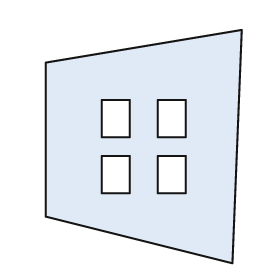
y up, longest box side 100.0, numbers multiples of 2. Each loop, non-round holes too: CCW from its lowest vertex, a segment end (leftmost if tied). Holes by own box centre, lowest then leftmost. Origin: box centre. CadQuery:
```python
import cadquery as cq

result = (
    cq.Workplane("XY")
    .moveTo(38.0, -50.0)
    .lineTo(42.0, 50.0)
    .lineTo(-42.0, 36.0)
    .lineTo(-42.0, -30.0)
    .close()
    .moveTo(-18.0, -20.0)
    .lineTo(-6.0, -20.0)
    .lineTo(-6.0, -4.0)
    .lineTo(-18.0, -4.0)
    .close()
    .moveTo(6.0, -20.0)
    .lineTo(18.0, -20.0)
    .lineTo(18.0, -4.0)
    .lineTo(6.0, -4.0)
    .close()
    .moveTo(-18.0, 4.0)
    .lineTo(-6.0, 4.0)
    .lineTo(-6.0, 20.0)
    .lineTo(-18.0, 20.0)
    .close()
    .moveTo(6.0, 4.0)
    .lineTo(18.0, 4.0)
    .lineTo(18.0, 20.0)
    .lineTo(6.0, 20.0)
    .close()
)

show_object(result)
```